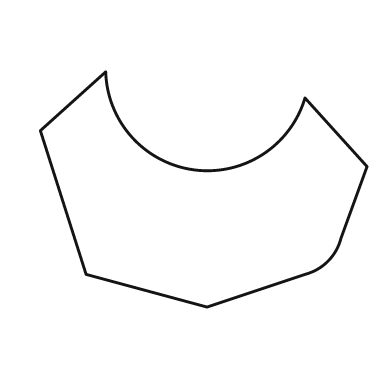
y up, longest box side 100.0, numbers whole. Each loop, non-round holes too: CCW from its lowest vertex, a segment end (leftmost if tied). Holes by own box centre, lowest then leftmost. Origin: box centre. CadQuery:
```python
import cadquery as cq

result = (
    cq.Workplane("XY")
    .moveTo(1.0, -36.0)
    .lineTo(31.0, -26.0)
    .threePointArc((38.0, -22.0), (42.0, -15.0))
    .lineTo(50.0, 7.0)
    .lineTo(31.0, 28.0)
    .threePointArc((-3.0, 6.0), (-30.0, 36.0))
    .lineTo(-50.0, 18.0)
    .lineTo(-36.0, -26.0)
    .close()
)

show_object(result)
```